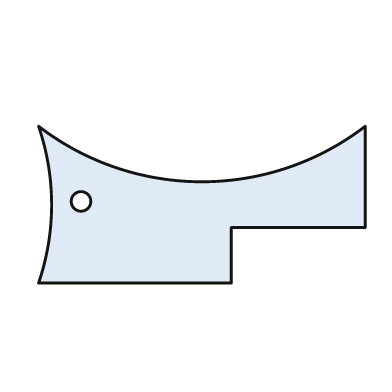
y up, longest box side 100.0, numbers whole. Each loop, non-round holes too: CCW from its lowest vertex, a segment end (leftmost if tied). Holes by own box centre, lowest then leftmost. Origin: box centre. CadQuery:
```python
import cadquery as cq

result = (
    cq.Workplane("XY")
    .moveTo(-50.0, -24.0)
    .lineTo(9.0, -24.0)
    .lineTo(9.0, -7.0)
    .lineTo(50.0, -7.0)
    .lineTo(50.0, 24.0)
    .threePointArc((0.0, 7.0), (-50.0, 24.0))
    .threePointArc((-46.0, 0.0), (-50.0, -24.0))
    .close()
    .moveTo(-37.0, 1.0)
    .circle(3.0)
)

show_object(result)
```